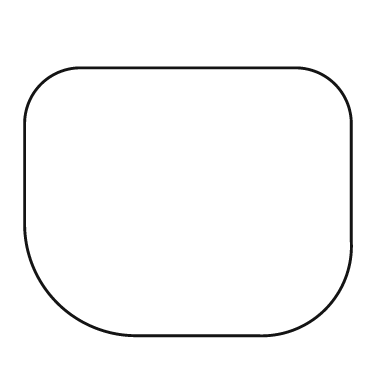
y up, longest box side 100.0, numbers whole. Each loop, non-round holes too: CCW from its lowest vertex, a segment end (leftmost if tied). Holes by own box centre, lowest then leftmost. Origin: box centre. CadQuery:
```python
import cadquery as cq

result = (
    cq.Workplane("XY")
    .moveTo(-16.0, -41.0)
    .lineTo(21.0, -41.0)
    .threePointArc((42.0, -33.0), (50.0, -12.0))
    .lineTo(50.0, 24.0)
    .threePointArc((45.0, 36.0), (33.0, 41.0))
    .lineTo(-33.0, 41.0)
    .threePointArc((-45.0, 36.0), (-50.0, 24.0))
    .lineTo(-50.0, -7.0)
    .threePointArc((-40.0, -31.0), (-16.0, -41.0))
    .close()
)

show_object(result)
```